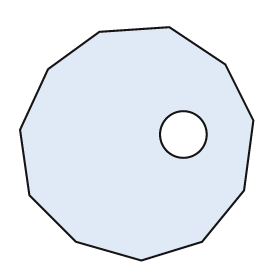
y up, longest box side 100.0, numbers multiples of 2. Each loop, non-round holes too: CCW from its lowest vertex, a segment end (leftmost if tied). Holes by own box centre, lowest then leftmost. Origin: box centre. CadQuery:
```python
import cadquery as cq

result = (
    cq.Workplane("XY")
    .moveTo(2.0, -50.0)
    .lineTo(28.0, -42.0)
    .lineTo(46.0, -20.0)
    .lineTo(50.0, 10.0)
    .lineTo(38.0, 34.0)
    .lineTo(14.0, 50.0)
    .lineTo(-16.0, 48.0)
    .lineTo(-38.0, 32.0)
    .lineTo(-50.0, 6.0)
    .lineTo(-46.0, -22.0)
    .lineTo(-26.0, -42.0)
    .close()
    .moveTo(20.0, 4.0)
    .circle(10.0)
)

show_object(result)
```